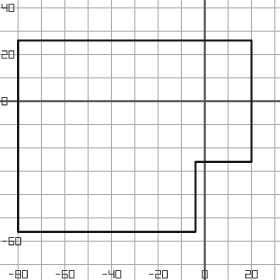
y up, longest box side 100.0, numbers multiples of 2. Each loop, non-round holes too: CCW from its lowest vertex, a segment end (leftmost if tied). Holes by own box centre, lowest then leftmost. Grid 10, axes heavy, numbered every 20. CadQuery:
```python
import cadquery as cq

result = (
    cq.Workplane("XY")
    .moveTo(-80.0, -56.0)
    .lineTo(-4.0, -56.0)
    .lineTo(-4.0, -26.0)
    .lineTo(20.0, -26.0)
    .lineTo(20.0, 26.0)
    .lineTo(-80.0, 26.0)
    .close()
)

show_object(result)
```